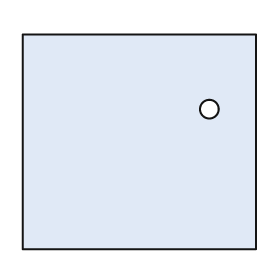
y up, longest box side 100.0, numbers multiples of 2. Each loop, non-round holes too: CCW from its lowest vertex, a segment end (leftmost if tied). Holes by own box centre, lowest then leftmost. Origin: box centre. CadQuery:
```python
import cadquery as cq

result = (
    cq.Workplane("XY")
    .moveTo(-50.0, -46.0)
    .lineTo(50.0, -46.0)
    .lineTo(50.0, 46.0)
    .lineTo(-50.0, 46.0)
    .close()
    .moveTo(30.0, 14.0)
    .circle(4.0)
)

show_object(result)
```